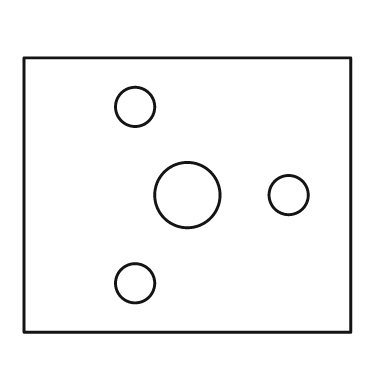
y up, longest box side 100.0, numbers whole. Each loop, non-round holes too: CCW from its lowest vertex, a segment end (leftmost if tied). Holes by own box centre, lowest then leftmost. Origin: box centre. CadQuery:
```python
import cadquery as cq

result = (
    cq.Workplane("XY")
    .moveTo(-50.0, -42.0)
    .lineTo(50.0, -42.0)
    .lineTo(50.0, 42.0)
    .lineTo(-50.0, 42.0)
    .close()
    .moveTo(-16.0, -27.0)
    .circle(6.0)
    .moveTo(0.0, 0.0)
    .circle(10.0)
    .moveTo(31.0, 0.0)
    .circle(6.0)
    .moveTo(-16.0, 27.0)
    .circle(6.0)
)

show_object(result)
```